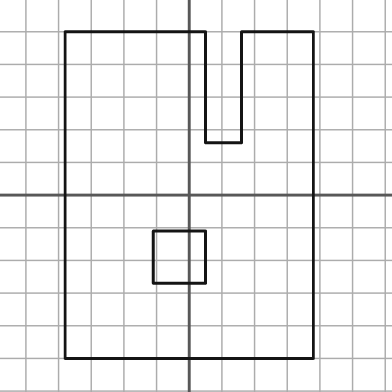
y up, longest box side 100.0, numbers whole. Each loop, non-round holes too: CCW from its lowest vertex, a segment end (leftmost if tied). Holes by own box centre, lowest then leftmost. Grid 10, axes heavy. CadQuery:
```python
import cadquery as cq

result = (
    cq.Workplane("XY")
    .moveTo(-38.0, -50.0)
    .lineTo(38.0, -50.0)
    .lineTo(38.0, 50.0)
    .lineTo(16.0, 50.0)
    .lineTo(16.0, 16.0)
    .lineTo(5.0, 16.0)
    .lineTo(5.0, 50.0)
    .lineTo(-38.0, 50.0)
    .close()
    .moveTo(-11.0, -27.0)
    .lineTo(5.0, -27.0)
    .lineTo(5.0, -11.0)
    .lineTo(-11.0, -11.0)
    .close()
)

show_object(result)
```